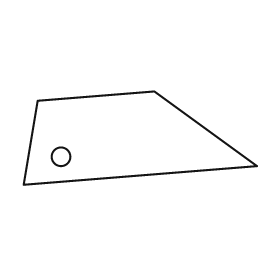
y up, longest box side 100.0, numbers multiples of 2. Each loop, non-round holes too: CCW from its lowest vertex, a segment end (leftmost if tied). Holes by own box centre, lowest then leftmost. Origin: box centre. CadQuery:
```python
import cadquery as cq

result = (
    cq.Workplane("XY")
    .moveTo(-50.0, -20.0)
    .lineTo(50.0, -12.0)
    .lineTo(6.0, 20.0)
    .lineTo(-44.0, 16.0)
    .close()
    .moveTo(-34.0, -8.0)
    .circle(4.0)
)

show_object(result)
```